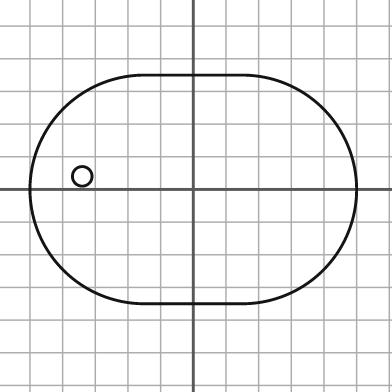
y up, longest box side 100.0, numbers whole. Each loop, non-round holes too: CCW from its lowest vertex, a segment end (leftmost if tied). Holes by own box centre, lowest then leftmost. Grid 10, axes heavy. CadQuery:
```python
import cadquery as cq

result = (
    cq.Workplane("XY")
    .moveTo(-15.0, -35.0)
    .lineTo(15.0, -35.0)
    .threePointArc((50.0, 0.0), (15.0, 35.0))
    .lineTo(-15.0, 35.0)
    .threePointArc((-50.0, 0.0), (-15.0, -35.0))
    .close()
    .moveTo(-34.0, 4.0)
    .circle(3.0)
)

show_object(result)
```